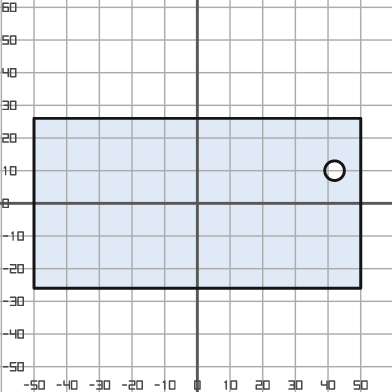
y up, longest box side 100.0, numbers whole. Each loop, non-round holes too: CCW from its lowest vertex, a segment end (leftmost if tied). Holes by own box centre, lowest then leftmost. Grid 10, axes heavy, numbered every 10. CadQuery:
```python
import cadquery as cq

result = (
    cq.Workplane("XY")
    .moveTo(-50.0, -26.0)
    .lineTo(50.0, -26.0)
    .lineTo(50.0, 26.0)
    .lineTo(-50.0, 26.0)
    .close()
    .moveTo(42.0, 10.0)
    .circle(3.0)
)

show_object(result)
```